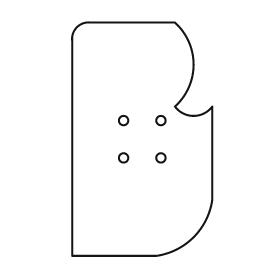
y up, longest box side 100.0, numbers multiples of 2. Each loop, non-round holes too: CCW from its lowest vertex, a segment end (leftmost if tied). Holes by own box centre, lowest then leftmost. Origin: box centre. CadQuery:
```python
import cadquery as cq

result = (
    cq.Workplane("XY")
    .moveTo(-30.0, -50.0)
    .lineTo(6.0, -50.0)
    .threePointArc((22.0, -42.0), (30.0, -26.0))
    .lineTo(30.0, 14.0)
    .threePointArc((22.0, 10.0), (14.0, 14.0))
    .threePointArc((22.0, 32.0), (14.0, 50.0))
    .lineTo(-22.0, 50.0)
    .threePointArc((-28.0, 48.0), (-30.0, 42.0))
    .close()
    .moveTo(-8.0, -8.0)
    .circle(2.0)
    .moveTo(8.0, -8.0)
    .circle(2.0)
    .moveTo(-8.0, 8.0)
    .circle(2.0)
    .moveTo(8.0, 8.0)
    .circle(2.0)
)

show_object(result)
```